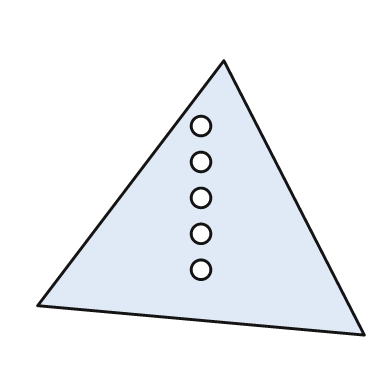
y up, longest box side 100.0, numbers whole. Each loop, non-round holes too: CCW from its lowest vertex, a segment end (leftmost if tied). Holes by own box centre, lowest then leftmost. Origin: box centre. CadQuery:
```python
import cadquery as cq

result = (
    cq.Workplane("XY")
    .moveTo(50.0, -42.0)
    .lineTo(7.0, 42.0)
    .lineTo(-50.0, -33.0)
    .close()
    .moveTo(0.0, -22.0)
    .circle(3.0)
    .moveTo(0.0, -11.0)
    .circle(3.0)
    .moveTo(0.0, 0.0)
    .circle(3.0)
    .moveTo(0.0, 11.0)
    .circle(3.0)
    .moveTo(0.0, 22.0)
    .circle(3.0)
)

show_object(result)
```